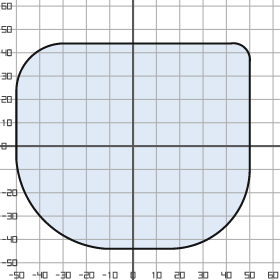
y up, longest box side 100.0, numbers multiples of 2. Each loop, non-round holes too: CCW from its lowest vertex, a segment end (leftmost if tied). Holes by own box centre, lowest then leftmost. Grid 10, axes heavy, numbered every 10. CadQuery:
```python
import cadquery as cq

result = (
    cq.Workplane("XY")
    .moveTo(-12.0, -44.0)
    .lineTo(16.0, -44.0)
    .threePointArc((40.0, -34.0), (50.0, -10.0))
    .lineTo(50.0, 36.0)
    .threePointArc((48.0, 42.0), (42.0, 44.0))
    .lineTo(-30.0, 44.0)
    .threePointArc((-44.0, 38.0), (-50.0, 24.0))
    .lineTo(-50.0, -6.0)
    .threePointArc((-38.0, -32.0), (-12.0, -44.0))
    .close()
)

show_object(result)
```